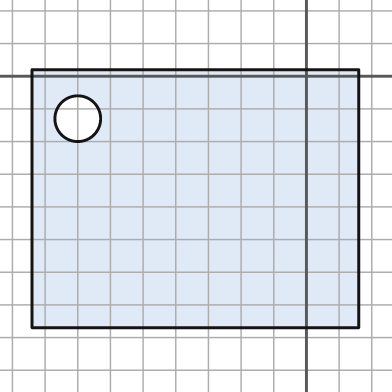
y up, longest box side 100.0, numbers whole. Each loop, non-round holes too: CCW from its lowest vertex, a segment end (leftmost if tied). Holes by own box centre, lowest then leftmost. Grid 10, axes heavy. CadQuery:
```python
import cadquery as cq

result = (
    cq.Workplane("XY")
    .moveTo(-84.0, -77.0)
    .lineTo(16.0, -77.0)
    .lineTo(16.0, 2.0)
    .lineTo(-84.0, 2.0)
    .close()
    .moveTo(-70.0, -13.0)
    .circle(7.0)
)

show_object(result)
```